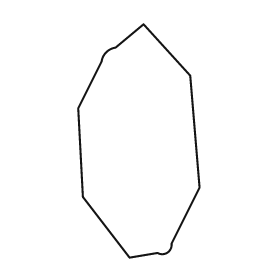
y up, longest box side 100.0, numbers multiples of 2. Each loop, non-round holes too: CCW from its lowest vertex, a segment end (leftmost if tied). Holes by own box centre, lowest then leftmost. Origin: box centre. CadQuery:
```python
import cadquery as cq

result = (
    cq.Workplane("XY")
    .moveTo(-4.0, -50.0)
    .lineTo(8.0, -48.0)
    .threePointArc((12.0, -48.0), (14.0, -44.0))
    .lineTo(26.0, -20.0)
    .lineTo(22.0, 28.0)
    .lineTo(2.0, 50.0)
    .lineTo(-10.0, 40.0)
    .threePointArc((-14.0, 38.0), (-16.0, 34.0))
    .lineTo(-26.0, 14.0)
    .lineTo(-24.0, -24.0)
    .close()
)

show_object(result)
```